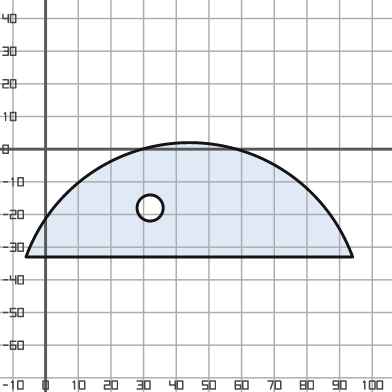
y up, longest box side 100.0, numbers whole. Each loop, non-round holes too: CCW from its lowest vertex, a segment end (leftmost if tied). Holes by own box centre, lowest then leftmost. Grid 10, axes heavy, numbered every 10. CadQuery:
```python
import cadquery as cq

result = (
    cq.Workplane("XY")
    .moveTo(-6.0, -33.0)
    .lineTo(94.0, -33.0)
    .threePointArc((44.0, 2.0), (-6.0, -33.0))
    .close()
    .moveTo(32.0, -18.0)
    .circle(4.0)
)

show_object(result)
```